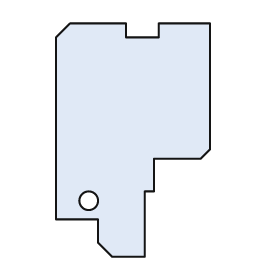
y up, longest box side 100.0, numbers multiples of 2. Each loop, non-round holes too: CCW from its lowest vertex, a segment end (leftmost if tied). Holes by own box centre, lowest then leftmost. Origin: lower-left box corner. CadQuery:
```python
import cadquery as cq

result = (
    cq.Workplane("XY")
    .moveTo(24.0, 0.0)
    .lineTo(38.0, 0.0)
    .lineTo(38.0, 28.0)
    .lineTo(42.0, 28.0)
    .lineTo(42.0, 42.0)
    .lineTo(62.0, 42.0)
    .lineTo(66.0, 46.0)
    .lineTo(66.0, 100.0)
    .lineTo(44.0, 100.0)
    .lineTo(44.0, 94.0)
    .lineTo(30.0, 94.0)
    .lineTo(30.0, 100.0)
    .lineTo(6.0, 100.0)
    .lineTo(0.0, 94.0)
    .lineTo(0.0, 16.0)
    .lineTo(18.0, 16.0)
    .lineTo(18.0, 6.0)
    .close()
    .moveTo(14.0, 24.0)
    .circle(4.0)
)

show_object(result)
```